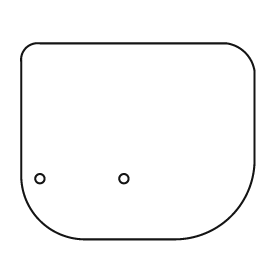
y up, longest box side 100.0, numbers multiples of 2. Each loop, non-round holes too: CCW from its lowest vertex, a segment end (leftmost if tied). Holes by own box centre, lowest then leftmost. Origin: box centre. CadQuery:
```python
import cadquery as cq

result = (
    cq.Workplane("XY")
    .moveTo(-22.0, -42.0)
    .lineTo(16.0, -42.0)
    .threePointArc((40.0, -32.0), (50.0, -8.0))
    .lineTo(50.0, 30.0)
    .threePointArc((46.0, 38.0), (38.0, 42.0))
    .lineTo(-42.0, 42.0)
    .threePointArc((-48.0, 40.0), (-50.0, 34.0))
    .lineTo(-50.0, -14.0)
    .threePointArc((-42.0, -34.0), (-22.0, -42.0))
    .close()
    .moveTo(-42.0, -16.0)
    .circle(2.0)
    .moveTo(-6.0, -16.0)
    .circle(2.0)
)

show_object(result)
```